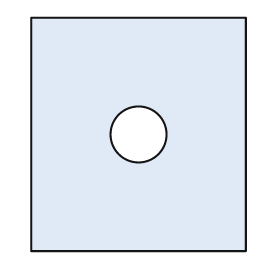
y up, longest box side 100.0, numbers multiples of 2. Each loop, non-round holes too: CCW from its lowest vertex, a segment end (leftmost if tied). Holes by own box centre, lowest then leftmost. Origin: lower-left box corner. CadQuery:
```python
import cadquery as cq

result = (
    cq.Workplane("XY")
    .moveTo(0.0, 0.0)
    .lineTo(92.0, 0.0)
    .lineTo(92.0, 100.0)
    .lineTo(0.0, 100.0)
    .close()
    .moveTo(46.0, 50.0)
    .circle(12.0)
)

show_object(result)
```